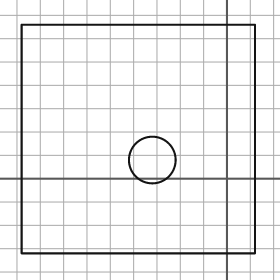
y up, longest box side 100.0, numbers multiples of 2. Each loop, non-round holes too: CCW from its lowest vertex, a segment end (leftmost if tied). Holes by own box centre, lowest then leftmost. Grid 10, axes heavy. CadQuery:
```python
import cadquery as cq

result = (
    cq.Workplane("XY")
    .moveTo(-88.0, -32.0)
    .lineTo(12.0, -32.0)
    .lineTo(12.0, 66.0)
    .lineTo(-88.0, 66.0)
    .close()
    .moveTo(-32.0, 8.0)
    .circle(10.0)
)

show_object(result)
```